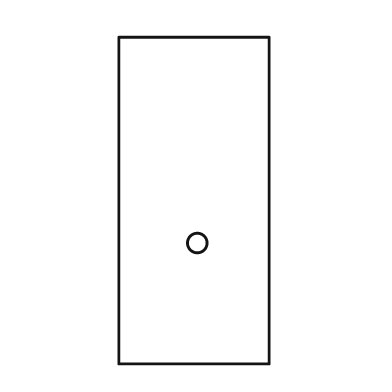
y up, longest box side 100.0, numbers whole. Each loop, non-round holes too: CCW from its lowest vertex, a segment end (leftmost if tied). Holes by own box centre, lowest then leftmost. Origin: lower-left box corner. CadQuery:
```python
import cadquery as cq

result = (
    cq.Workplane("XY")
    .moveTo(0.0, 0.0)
    .lineTo(46.0, 0.0)
    .lineTo(46.0, 100.0)
    .lineTo(0.0, 100.0)
    .close()
    .moveTo(24.0, 37.0)
    .circle(3.0)
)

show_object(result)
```